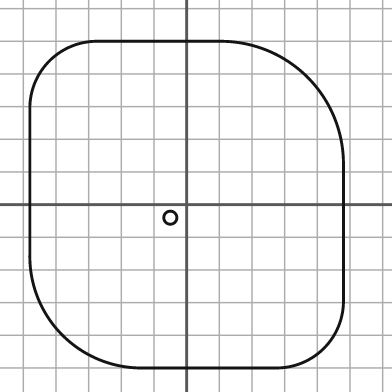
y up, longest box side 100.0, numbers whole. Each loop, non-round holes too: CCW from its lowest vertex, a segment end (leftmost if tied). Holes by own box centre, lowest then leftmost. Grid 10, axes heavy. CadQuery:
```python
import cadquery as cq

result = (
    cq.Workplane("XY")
    .moveTo(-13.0, -50.0)
    .lineTo(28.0, -50.0)
    .threePointArc((42.0, -44.0), (48.0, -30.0))
    .lineTo(48.0, 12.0)
    .threePointArc((37.0, 39.0), (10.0, 50.0))
    .lineTo(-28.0, 50.0)
    .threePointArc((-42.0, 44.0), (-48.0, 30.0))
    .lineTo(-48.0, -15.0)
    .threePointArc((-38.0, -40.0), (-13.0, -50.0))
    .close()
    .moveTo(-5.0, -4.0)
    .circle(2.0)
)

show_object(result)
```